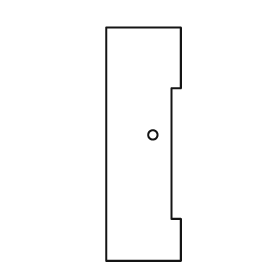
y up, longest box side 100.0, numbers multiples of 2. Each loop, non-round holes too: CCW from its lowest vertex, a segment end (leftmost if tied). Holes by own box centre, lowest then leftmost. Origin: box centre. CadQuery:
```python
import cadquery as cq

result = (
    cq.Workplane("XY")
    .moveTo(-16.0, -50.0)
    .lineTo(16.0, -50.0)
    .lineTo(16.0, -32.0)
    .lineTo(12.0, -32.0)
    .lineTo(12.0, 24.0)
    .lineTo(16.0, 24.0)
    .lineTo(16.0, 50.0)
    .lineTo(-16.0, 50.0)
    .close()
    .moveTo(4.0, 4.0)
    .circle(2.0)
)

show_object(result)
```